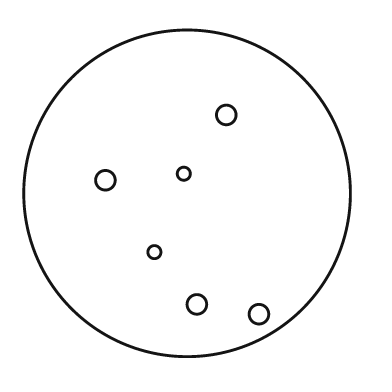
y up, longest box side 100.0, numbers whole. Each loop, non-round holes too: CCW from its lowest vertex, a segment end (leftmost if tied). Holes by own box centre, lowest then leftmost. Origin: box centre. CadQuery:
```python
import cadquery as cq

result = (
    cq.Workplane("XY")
    .moveTo(0.0, 0.0)
    .circle(50.0)
    .moveTo(22.0, -37.0)
    .circle(3.0)
    .moveTo(3.0, -34.0)
    .circle(3.0)
    .moveTo(-10.0, -18.0)
    .circle(2.0)
    .moveTo(-25.0, 4.0)
    .circle(3.0)
    .moveTo(-1.0, 6.0)
    .circle(2.0)
    .moveTo(12.0, 24.0)
    .circle(3.0)
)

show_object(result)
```